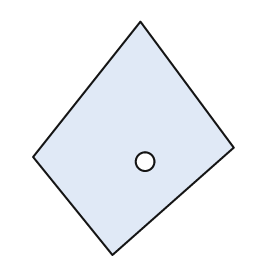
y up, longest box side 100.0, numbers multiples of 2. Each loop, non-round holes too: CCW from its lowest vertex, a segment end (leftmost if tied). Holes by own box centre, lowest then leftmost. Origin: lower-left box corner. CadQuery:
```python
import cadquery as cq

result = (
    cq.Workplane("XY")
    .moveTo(34.0, 0.0)
    .lineTo(86.0, 46.0)
    .lineTo(46.0, 100.0)
    .lineTo(0.0, 42.0)
    .close()
    .moveTo(48.0, 40.0)
    .circle(4.0)
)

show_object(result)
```